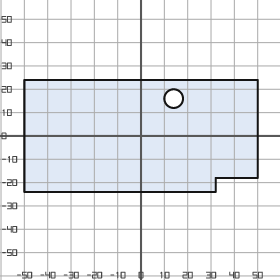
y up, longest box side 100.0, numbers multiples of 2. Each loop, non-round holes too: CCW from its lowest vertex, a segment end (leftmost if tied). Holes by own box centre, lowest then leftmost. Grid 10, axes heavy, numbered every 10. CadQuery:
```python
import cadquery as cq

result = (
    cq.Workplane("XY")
    .moveTo(-50.0, -24.0)
    .lineTo(32.0, -24.0)
    .lineTo(32.0, -18.0)
    .lineTo(50.0, -18.0)
    .lineTo(50.0, 24.0)
    .lineTo(-50.0, 24.0)
    .close()
    .moveTo(14.0, 16.0)
    .circle(4.0)
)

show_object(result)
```